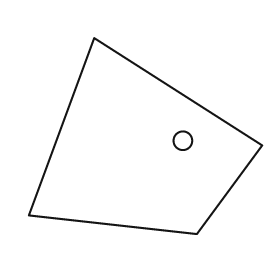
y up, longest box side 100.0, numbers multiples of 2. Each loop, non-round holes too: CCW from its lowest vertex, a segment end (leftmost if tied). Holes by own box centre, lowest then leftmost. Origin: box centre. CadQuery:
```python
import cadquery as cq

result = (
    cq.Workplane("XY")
    .moveTo(22.0, -42.0)
    .lineTo(50.0, -4.0)
    .lineTo(-22.0, 42.0)
    .lineTo(-50.0, -34.0)
    .close()
    .moveTo(16.0, -2.0)
    .circle(4.0)
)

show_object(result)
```